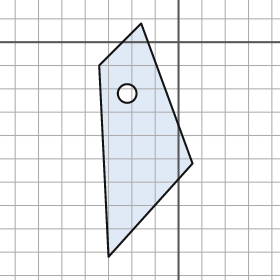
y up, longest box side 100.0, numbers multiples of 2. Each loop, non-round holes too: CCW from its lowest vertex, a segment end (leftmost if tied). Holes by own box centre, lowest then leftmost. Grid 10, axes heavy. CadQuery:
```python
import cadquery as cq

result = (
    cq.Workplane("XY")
    .moveTo(-30.0, -92.0)
    .lineTo(6.0, -52.0)
    .lineTo(-16.0, 8.0)
    .lineTo(-34.0, -10.0)
    .close()
    .moveTo(-22.0, -22.0)
    .circle(4.0)
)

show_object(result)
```